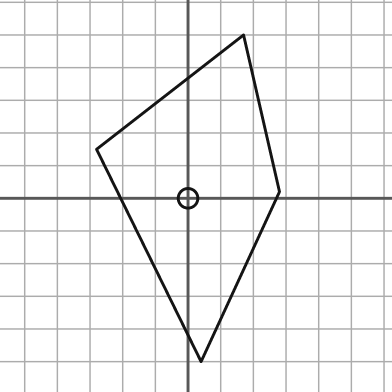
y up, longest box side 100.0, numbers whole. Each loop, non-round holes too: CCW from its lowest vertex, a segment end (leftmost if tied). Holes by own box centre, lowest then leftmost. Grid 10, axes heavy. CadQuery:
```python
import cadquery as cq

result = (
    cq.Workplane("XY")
    .moveTo(4.0, -50.0)
    .lineTo(28.0, 2.0)
    .lineTo(17.0, 50.0)
    .lineTo(-28.0, 15.0)
    .close()
    .moveTo(0.0, 0.0)
    .circle(3.0)
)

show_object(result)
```